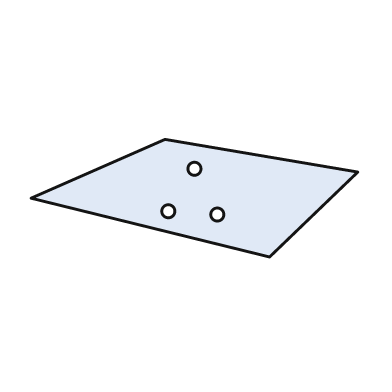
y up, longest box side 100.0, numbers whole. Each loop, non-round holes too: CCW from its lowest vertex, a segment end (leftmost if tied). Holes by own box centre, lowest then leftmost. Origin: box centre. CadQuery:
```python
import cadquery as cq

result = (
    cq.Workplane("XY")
    .moveTo(23.0, -18.0)
    .lineTo(50.0, 8.0)
    .lineTo(-9.0, 18.0)
    .lineTo(-50.0, 0.0)
    .close()
    .moveTo(7.0, -5.0)
    .circle(2.0)
    .moveTo(-8.0, -4.0)
    .circle(2.0)
    .moveTo(0.0, 9.0)
    .circle(2.0)
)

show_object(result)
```